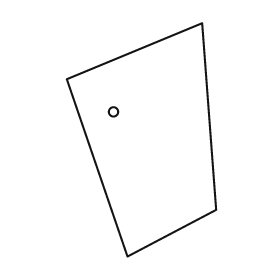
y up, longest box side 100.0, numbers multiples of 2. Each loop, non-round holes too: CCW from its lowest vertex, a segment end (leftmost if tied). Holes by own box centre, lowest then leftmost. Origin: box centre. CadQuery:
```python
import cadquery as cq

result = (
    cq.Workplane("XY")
    .moveTo(-6.0, -50.0)
    .lineTo(32.0, -30.0)
    .lineTo(26.0, 50.0)
    .lineTo(-32.0, 26.0)
    .close()
    .moveTo(-12.0, 12.0)
    .circle(2.0)
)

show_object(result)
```